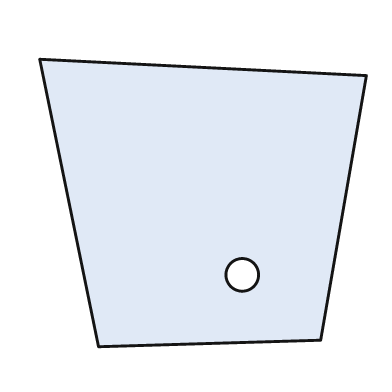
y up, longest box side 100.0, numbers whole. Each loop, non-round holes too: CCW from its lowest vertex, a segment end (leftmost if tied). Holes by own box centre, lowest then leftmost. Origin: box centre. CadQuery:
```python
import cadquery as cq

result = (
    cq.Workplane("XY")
    .moveTo(-32.0, -44.0)
    .lineTo(36.0, -42.0)
    .lineTo(50.0, 39.0)
    .lineTo(-50.0, 44.0)
    .close()
    .moveTo(12.0, -22.0)
    .circle(5.0)
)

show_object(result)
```